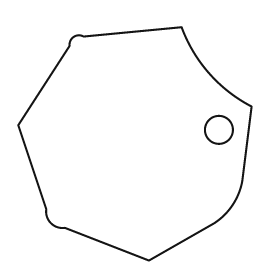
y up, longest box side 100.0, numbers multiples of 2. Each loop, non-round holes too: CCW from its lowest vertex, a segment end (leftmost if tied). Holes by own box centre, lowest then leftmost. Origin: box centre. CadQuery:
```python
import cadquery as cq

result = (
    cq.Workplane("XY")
    .moveTo(6.0, -50.0)
    .lineTo(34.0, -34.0)
    .threePointArc((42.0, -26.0), (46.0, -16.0))
    .lineTo(50.0, 16.0)
    .threePointArc((32.0, 30.0), (20.0, 50.0))
    .lineTo(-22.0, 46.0)
    .threePointArc((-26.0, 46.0), (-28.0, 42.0))
    .lineTo(-50.0, 8.0)
    .lineTo(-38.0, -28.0)
    .threePointArc((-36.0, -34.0), (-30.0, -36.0))
    .close()
    .moveTo(36.0, 6.0)
    .circle(6.0)
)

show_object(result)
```